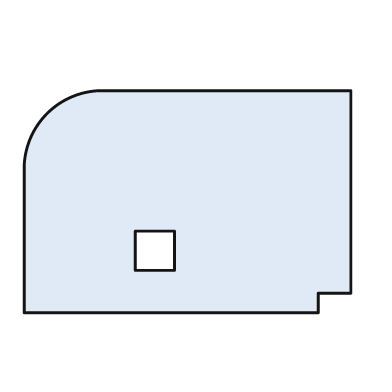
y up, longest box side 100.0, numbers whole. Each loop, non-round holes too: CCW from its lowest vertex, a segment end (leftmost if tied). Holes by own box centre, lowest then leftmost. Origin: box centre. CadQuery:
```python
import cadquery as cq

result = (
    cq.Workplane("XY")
    .moveTo(-50.0, -34.0)
    .lineTo(40.0, -34.0)
    .lineTo(40.0, -28.0)
    .lineTo(50.0, -28.0)
    .lineTo(50.0, 34.0)
    .lineTo(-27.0, 34.0)
    .threePointArc((-43.0, 27.0), (-50.0, 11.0))
    .close()
    .moveTo(-16.0, -21.0)
    .lineTo(-4.0, -21.0)
    .lineTo(-4.0, -9.0)
    .lineTo(-16.0, -9.0)
    .close()
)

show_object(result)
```